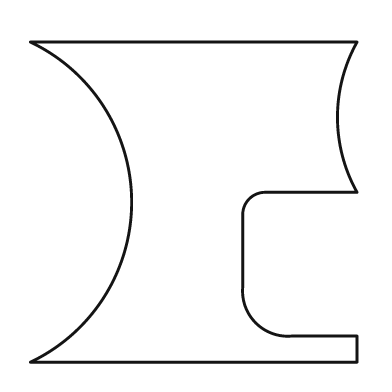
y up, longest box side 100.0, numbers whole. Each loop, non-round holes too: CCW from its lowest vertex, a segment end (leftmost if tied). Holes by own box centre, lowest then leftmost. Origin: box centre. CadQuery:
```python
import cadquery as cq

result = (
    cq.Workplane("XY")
    .moveTo(-50.0, -49.0)
    .lineTo(50.0, -49.0)
    .lineTo(50.0, -41.0)
    .lineTo(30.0, -41.0)
    .threePointArc((19.0, -37.0), (15.0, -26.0))
    .lineTo(15.0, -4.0)
    .threePointArc((17.0, 1.0), (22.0, 3.0))
    .lineTo(50.0, 3.0)
    .threePointArc((44.0, 26.0), (50.0, 49.0))
    .lineTo(-50.0, 49.0)
    .threePointArc((-19.0, 0.0), (-50.0, -49.0))
    .close()
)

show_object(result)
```